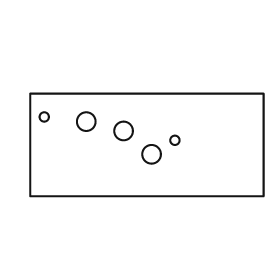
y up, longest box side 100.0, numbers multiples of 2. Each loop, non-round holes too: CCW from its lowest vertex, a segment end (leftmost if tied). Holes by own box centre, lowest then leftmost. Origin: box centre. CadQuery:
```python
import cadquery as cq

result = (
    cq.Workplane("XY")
    .moveTo(-50.0, -22.0)
    .lineTo(50.0, -22.0)
    .lineTo(50.0, 22.0)
    .lineTo(-50.0, 22.0)
    .close()
    .moveTo(2.0, -4.0)
    .circle(4.0)
    .moveTo(12.0, 2.0)
    .circle(2.0)
    .moveTo(-10.0, 6.0)
    .circle(4.0)
    .moveTo(-26.0, 10.0)
    .circle(4.0)
    .moveTo(-44.0, 12.0)
    .circle(2.0)
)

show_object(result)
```